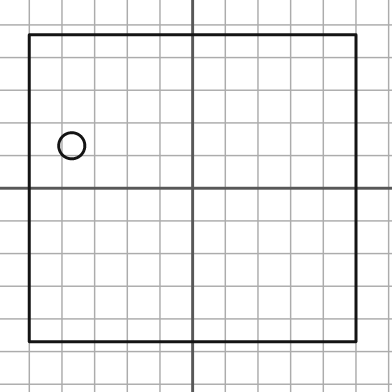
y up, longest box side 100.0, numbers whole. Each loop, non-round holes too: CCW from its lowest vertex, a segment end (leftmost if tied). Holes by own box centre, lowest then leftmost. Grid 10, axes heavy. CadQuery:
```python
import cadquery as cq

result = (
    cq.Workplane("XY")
    .moveTo(-50.0, -47.0)
    .lineTo(50.0, -47.0)
    .lineTo(50.0, 47.0)
    .lineTo(-50.0, 47.0)
    .close()
    .moveTo(-37.0, 13.0)
    .circle(4.0)
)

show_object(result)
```